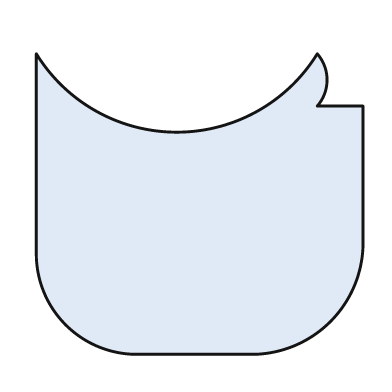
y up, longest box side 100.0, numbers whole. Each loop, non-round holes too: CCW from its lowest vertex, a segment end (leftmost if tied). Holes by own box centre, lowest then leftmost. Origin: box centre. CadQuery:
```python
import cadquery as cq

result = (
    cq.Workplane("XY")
    .moveTo(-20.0, -46.0)
    .lineTo(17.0, -46.0)
    .threePointArc((40.0, -36.0), (50.0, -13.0))
    .lineTo(50.0, 30.0)
    .lineTo(36.0, 30.0)
    .threePointArc((39.0, 38.0), (36.0, 46.0))
    .threePointArc((-7.0, 22.0), (-50.0, 46.0))
    .lineTo(-50.0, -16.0)
    .threePointArc((-41.0, -37.0), (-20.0, -46.0))
    .close()
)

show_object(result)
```